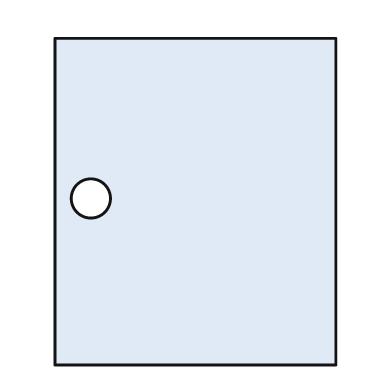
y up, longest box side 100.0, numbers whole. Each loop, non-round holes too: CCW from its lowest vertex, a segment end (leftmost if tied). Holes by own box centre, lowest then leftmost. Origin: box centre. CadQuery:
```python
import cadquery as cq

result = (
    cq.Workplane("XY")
    .moveTo(-43.0, -50.0)
    .lineTo(43.0, -50.0)
    .lineTo(43.0, 50.0)
    .lineTo(-43.0, 50.0)
    .close()
    .moveTo(-32.0, 1.0)
    .circle(6.0)
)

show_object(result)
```